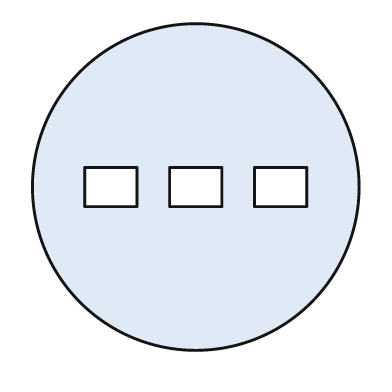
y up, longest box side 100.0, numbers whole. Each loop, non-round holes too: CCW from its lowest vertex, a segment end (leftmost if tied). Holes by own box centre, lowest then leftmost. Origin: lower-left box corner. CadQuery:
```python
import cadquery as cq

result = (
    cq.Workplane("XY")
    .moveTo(50.0, 50.0)
    .circle(50.0)
    .moveTo(16.0, 44.0)
    .lineTo(32.0, 44.0)
    .lineTo(32.0, 56.0)
    .lineTo(16.0, 56.0)
    .close()
    .moveTo(42.0, 44.0)
    .lineTo(58.0, 44.0)
    .lineTo(58.0, 56.0)
    .lineTo(42.0, 56.0)
    .close()
    .moveTo(68.0, 44.0)
    .lineTo(84.0, 44.0)
    .lineTo(84.0, 56.0)
    .lineTo(68.0, 56.0)
    .close()
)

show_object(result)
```